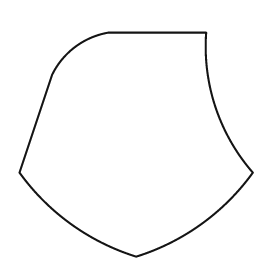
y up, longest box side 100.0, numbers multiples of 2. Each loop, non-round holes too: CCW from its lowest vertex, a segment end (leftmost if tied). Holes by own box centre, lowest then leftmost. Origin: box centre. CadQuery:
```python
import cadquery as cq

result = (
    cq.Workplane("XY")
    .moveTo(0.0, -48.0)
    .threePointArc((28.0, -34.0), (50.0, -12.0))
    .threePointArc((34.0, 16.0), (30.0, 48.0))
    .lineTo(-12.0, 48.0)
    .threePointArc((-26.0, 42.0), (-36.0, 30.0))
    .lineTo(-50.0, -12.0)
    .threePointArc((-28.0, -34.0), (0.0, -48.0))
    .close()
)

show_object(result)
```